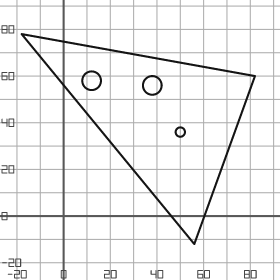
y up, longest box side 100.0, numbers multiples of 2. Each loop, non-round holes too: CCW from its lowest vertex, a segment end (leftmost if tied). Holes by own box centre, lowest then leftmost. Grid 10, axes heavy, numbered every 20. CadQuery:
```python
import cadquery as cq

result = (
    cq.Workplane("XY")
    .moveTo(56.0, -12.0)
    .lineTo(82.0, 60.0)
    .lineTo(-18.0, 78.0)
    .close()
    .moveTo(50.0, 36.0)
    .circle(2.0)
    .moveTo(38.0, 56.0)
    .circle(4.0)
    .moveTo(12.0, 58.0)
    .circle(4.0)
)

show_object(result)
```